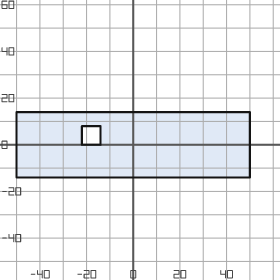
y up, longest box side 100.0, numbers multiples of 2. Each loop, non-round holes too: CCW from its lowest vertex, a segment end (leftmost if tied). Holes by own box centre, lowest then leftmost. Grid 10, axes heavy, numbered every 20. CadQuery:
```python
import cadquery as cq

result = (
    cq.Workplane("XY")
    .moveTo(-50.0, -14.0)
    .lineTo(50.0, -14.0)
    .lineTo(50.0, 14.0)
    .lineTo(-50.0, 14.0)
    .close()
    .moveTo(-22.0, 0.0)
    .lineTo(-14.0, 0.0)
    .lineTo(-14.0, 8.0)
    .lineTo(-22.0, 8.0)
    .close()
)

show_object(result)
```